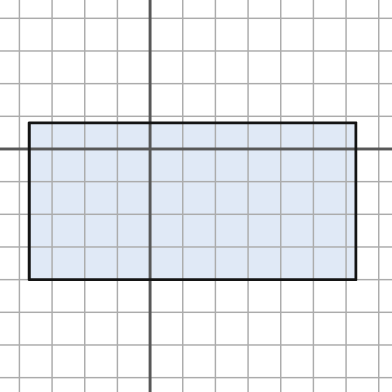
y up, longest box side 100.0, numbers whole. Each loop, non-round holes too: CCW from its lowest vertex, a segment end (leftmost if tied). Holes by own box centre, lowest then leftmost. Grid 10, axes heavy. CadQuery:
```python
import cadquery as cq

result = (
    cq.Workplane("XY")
    .moveTo(-37.0, -40.0)
    .lineTo(63.0, -40.0)
    .lineTo(63.0, 8.0)
    .lineTo(-37.0, 8.0)
    .close()
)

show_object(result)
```